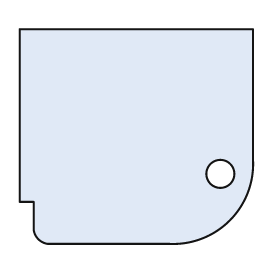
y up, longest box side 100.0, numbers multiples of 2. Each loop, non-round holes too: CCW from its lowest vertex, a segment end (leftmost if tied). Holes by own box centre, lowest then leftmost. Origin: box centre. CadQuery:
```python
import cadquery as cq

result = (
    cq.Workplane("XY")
    .moveTo(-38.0, -46.0)
    .lineTo(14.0, -46.0)
    .threePointArc((40.0, -36.0), (50.0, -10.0))
    .lineTo(50.0, 46.0)
    .lineTo(-50.0, 46.0)
    .lineTo(-50.0, -28.0)
    .lineTo(-44.0, -28.0)
    .lineTo(-44.0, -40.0)
    .threePointArc((-42.0, -44.0), (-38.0, -46.0))
    .close()
    .moveTo(36.0, -16.0)
    .circle(6.0)
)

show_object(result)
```